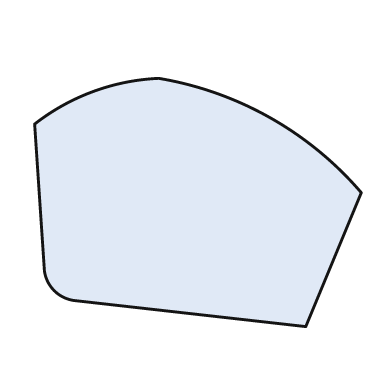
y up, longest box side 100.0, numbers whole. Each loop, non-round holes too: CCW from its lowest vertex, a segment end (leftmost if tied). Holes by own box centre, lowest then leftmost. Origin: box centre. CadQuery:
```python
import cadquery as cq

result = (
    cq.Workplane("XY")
    .moveTo(33.0, -38.0)
    .lineTo(50.0, 3.0)
    .threePointArc((22.0, 26.0), (-12.0, 38.0))
    .threePointArc((-32.0, 34.0), (-50.0, 24.0))
    .lineTo(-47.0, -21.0)
    .threePointArc((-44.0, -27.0), (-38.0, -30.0))
    .close()
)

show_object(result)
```